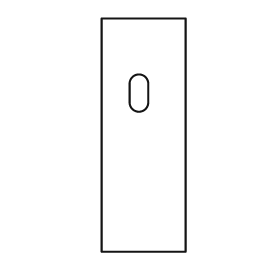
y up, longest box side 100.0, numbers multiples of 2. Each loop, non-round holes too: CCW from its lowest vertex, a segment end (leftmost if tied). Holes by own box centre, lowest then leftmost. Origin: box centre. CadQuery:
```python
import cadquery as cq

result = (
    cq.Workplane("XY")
    .moveTo(-18.0, -50.0)
    .lineTo(18.0, -50.0)
    .lineTo(18.0, 50.0)
    .lineTo(-18.0, 50.0)
    .close()
    .moveTo(-6.0, 14.0)
    .threePointArc((-2.0, 10.0), (2.0, 14.0))
    .lineTo(2.0, 22.0)
    .threePointArc((-2.0, 26.0), (-6.0, 22.0))
    .close()
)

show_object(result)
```